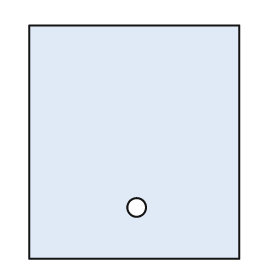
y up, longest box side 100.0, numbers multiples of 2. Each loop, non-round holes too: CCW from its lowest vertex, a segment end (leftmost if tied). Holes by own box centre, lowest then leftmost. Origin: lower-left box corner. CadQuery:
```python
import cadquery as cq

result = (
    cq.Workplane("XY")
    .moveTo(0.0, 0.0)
    .lineTo(90.0, 0.0)
    .lineTo(90.0, 100.0)
    .lineTo(0.0, 100.0)
    .close()
    .moveTo(46.0, 22.0)
    .circle(4.0)
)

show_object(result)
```